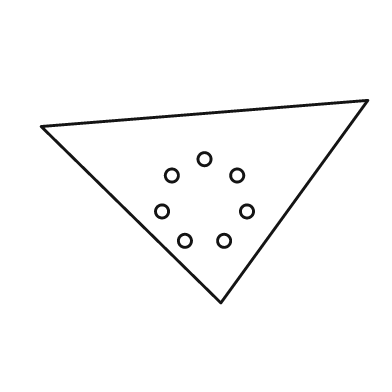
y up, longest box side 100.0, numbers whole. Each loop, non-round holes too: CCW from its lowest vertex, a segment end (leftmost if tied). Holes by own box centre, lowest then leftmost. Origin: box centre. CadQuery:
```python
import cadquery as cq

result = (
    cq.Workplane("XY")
    .moveTo(5.0, -31.0)
    .lineTo(50.0, 31.0)
    .lineTo(-50.0, 23.0)
    .close()
    .moveTo(-6.0, -12.0)
    .circle(2.0)
    .moveTo(6.0, -12.0)
    .circle(2.0)
    .moveTo(-13.0, -3.0)
    .circle(2.0)
    .moveTo(13.0, -3.0)
    .circle(2.0)
    .moveTo(-10.0, 8.0)
    .circle(2.0)
    .moveTo(10.0, 8.0)
    .circle(2.0)
    .moveTo(0.0, 13.0)
    .circle(2.0)
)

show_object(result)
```